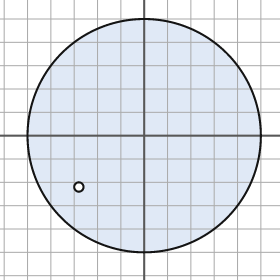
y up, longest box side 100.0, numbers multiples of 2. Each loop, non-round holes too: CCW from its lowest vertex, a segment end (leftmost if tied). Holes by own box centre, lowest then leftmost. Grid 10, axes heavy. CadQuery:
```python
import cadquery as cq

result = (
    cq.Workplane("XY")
    .moveTo(0.0, 0.0)
    .circle(50.0)
    .moveTo(-28.0, -22.0)
    .circle(2.0)
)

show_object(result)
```